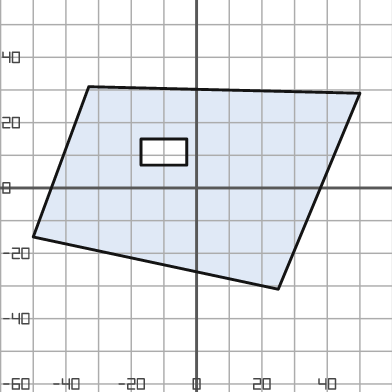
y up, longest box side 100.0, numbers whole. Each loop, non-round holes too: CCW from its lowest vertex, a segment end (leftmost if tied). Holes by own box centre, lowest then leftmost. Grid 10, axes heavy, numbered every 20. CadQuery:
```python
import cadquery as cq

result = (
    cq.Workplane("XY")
    .moveTo(25.0, -31.0)
    .lineTo(50.0, 29.0)
    .lineTo(-33.0, 31.0)
    .lineTo(-50.0, -15.0)
    .close()
    .moveTo(-17.0, 7.0)
    .lineTo(-3.0, 7.0)
    .lineTo(-3.0, 15.0)
    .lineTo(-17.0, 15.0)
    .close()
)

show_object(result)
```